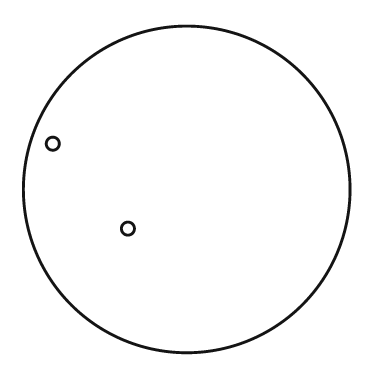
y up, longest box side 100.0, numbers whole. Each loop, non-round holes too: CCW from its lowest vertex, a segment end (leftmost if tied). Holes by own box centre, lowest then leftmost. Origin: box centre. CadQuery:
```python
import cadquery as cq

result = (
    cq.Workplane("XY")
    .moveTo(0.0, 0.0)
    .circle(50.0)
    .moveTo(-18.0, -12.0)
    .circle(2.0)
    .moveTo(-41.0, 14.0)
    .circle(2.0)
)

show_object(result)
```